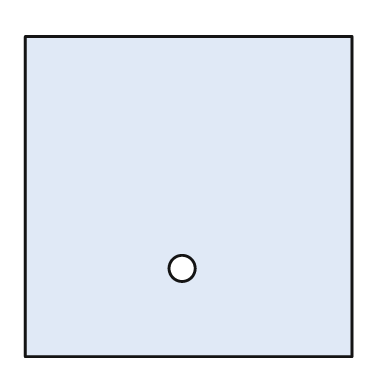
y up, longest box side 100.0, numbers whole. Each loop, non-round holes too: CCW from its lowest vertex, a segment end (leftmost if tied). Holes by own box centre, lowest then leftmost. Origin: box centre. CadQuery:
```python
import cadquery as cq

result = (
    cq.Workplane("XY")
    .moveTo(-50.0, -49.0)
    .lineTo(50.0, -49.0)
    .lineTo(50.0, 49.0)
    .lineTo(-50.0, 49.0)
    .close()
    .moveTo(-2.0, -22.0)
    .circle(4.0)
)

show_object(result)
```